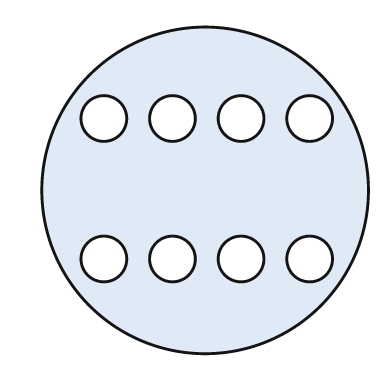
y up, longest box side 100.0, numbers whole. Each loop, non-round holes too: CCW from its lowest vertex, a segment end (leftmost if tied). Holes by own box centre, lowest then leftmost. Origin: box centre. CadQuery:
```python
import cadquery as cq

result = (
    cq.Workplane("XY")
    .moveTo(0.0, 0.0)
    .circle(50.0)
    .moveTo(-31.0, -21.0)
    .circle(7.0)
    .moveTo(-10.0, -21.0)
    .circle(7.0)
    .moveTo(11.0, -21.0)
    .circle(7.0)
    .moveTo(32.0, -21.0)
    .circle(7.0)
    .moveTo(-31.0, 22.0)
    .circle(7.0)
    .moveTo(-10.0, 22.0)
    .circle(7.0)
    .moveTo(11.0, 22.0)
    .circle(7.0)
    .moveTo(32.0, 22.0)
    .circle(7.0)
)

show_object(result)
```